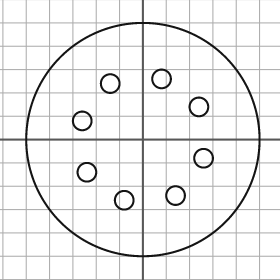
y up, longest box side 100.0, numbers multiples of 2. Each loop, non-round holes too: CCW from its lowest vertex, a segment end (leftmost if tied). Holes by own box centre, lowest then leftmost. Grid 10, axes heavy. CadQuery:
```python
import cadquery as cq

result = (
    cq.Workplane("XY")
    .moveTo(0.0, 0.0)
    .circle(50.0)
    .moveTo(-8.0, -26.0)
    .circle(4.0)
    .moveTo(14.0, -24.0)
    .circle(4.0)
    .moveTo(-24.0, -14.0)
    .circle(4.0)
    .moveTo(26.0, -8.0)
    .circle(4.0)
    .moveTo(-26.0, 8.0)
    .circle(4.0)
    .moveTo(24.0, 14.0)
    .circle(4.0)
    .moveTo(-14.0, 24.0)
    .circle(4.0)
    .moveTo(8.0, 26.0)
    .circle(4.0)
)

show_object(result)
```